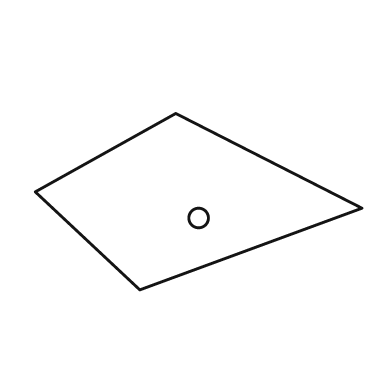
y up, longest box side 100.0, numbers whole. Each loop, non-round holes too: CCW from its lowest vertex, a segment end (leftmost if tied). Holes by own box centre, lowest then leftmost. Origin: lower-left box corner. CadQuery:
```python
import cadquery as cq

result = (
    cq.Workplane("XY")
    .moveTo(32.0, 0.0)
    .lineTo(100.0, 25.0)
    .lineTo(43.0, 54.0)
    .lineTo(0.0, 30.0)
    .close()
    .moveTo(50.0, 22.0)
    .circle(3.0)
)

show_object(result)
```